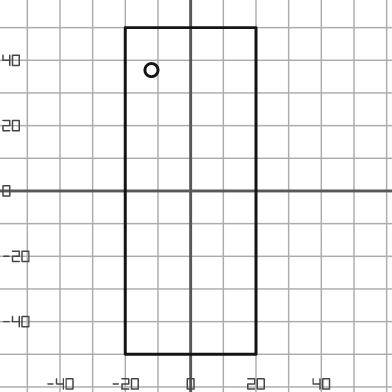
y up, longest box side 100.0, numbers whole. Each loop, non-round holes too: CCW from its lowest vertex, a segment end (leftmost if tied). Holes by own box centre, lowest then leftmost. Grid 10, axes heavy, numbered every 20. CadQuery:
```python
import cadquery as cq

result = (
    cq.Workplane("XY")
    .moveTo(-20.0, -50.0)
    .lineTo(20.0, -50.0)
    .lineTo(20.0, 50.0)
    .lineTo(-20.0, 50.0)
    .close()
    .moveTo(-12.0, 37.0)
    .circle(2.0)
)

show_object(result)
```